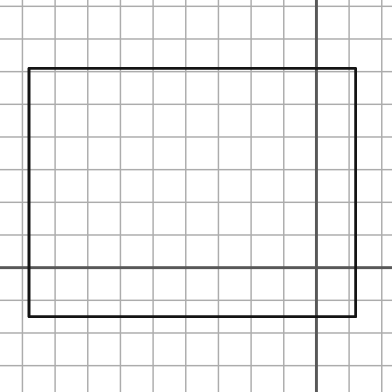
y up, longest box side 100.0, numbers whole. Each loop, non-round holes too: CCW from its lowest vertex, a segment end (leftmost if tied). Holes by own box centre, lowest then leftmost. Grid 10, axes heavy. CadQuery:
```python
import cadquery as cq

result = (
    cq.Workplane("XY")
    .moveTo(-88.0, -15.0)
    .lineTo(12.0, -15.0)
    .lineTo(12.0, 61.0)
    .lineTo(-88.0, 61.0)
    .close()
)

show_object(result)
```